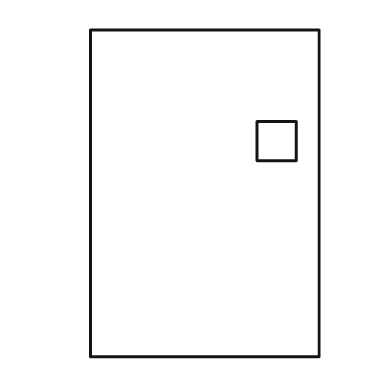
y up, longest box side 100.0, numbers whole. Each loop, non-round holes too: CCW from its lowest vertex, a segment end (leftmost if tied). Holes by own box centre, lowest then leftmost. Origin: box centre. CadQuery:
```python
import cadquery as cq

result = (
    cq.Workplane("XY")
    .moveTo(-35.0, -50.0)
    .lineTo(35.0, -50.0)
    .lineTo(35.0, 50.0)
    .lineTo(-35.0, 50.0)
    .close()
    .moveTo(16.0, 10.0)
    .lineTo(28.0, 10.0)
    .lineTo(28.0, 22.0)
    .lineTo(16.0, 22.0)
    .close()
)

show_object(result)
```